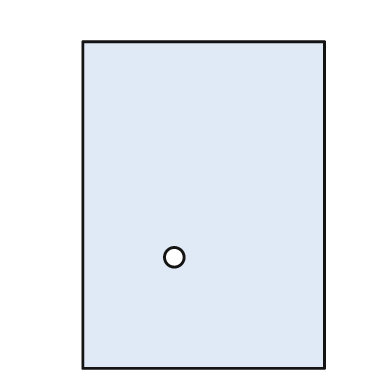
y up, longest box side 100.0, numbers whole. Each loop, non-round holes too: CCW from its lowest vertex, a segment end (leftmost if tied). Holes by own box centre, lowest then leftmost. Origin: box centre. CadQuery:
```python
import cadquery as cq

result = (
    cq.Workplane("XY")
    .moveTo(-37.0, -50.0)
    .lineTo(37.0, -50.0)
    .lineTo(37.0, 50.0)
    .lineTo(-37.0, 50.0)
    .close()
    .moveTo(-9.0, -16.0)
    .circle(3.0)
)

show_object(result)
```